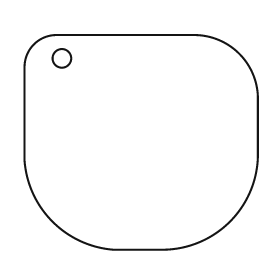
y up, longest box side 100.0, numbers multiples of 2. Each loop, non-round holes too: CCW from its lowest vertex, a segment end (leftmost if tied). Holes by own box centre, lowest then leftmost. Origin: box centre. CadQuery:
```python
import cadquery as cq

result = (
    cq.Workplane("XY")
    .moveTo(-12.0, -46.0)
    .lineTo(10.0, -46.0)
    .threePointArc((38.0, -34.0), (50.0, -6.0))
    .lineTo(50.0, 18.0)
    .threePointArc((42.0, 38.0), (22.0, 46.0))
    .lineTo(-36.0, 46.0)
    .threePointArc((-46.0, 42.0), (-50.0, 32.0))
    .lineTo(-50.0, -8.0)
    .threePointArc((-38.0, -34.0), (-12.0, -46.0))
    .close()
    .moveTo(-34.0, 36.0)
    .circle(4.0)
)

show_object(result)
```